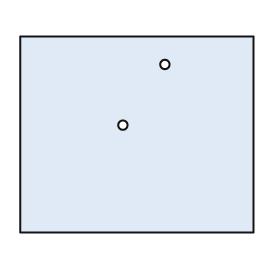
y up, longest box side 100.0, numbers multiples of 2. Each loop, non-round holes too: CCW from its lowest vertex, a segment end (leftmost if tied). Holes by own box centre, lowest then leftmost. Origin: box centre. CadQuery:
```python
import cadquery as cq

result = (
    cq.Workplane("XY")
    .moveTo(-50.0, -42.0)
    .lineTo(50.0, -42.0)
    .lineTo(50.0, 42.0)
    .lineTo(-50.0, 42.0)
    .close()
    .moveTo(-6.0, 4.0)
    .circle(2.0)
    .moveTo(12.0, 30.0)
    .circle(2.0)
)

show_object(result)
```